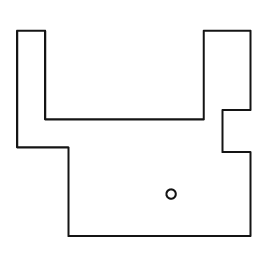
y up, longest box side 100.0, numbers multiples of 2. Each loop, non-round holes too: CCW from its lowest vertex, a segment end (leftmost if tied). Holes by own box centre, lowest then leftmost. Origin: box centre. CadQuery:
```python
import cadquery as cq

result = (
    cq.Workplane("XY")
    .moveTo(-28.0, -44.0)
    .lineTo(50.0, -44.0)
    .lineTo(50.0, -8.0)
    .lineTo(38.0, -8.0)
    .lineTo(38.0, 10.0)
    .lineTo(50.0, 10.0)
    .lineTo(50.0, 44.0)
    .lineTo(30.0, 44.0)
    .lineTo(30.0, 6.0)
    .lineTo(-38.0, 6.0)
    .lineTo(-38.0, 44.0)
    .lineTo(-50.0, 44.0)
    .lineTo(-50.0, -6.0)
    .lineTo(-28.0, -6.0)
    .close()
    .moveTo(16.0, -26.0)
    .circle(2.0)
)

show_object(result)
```